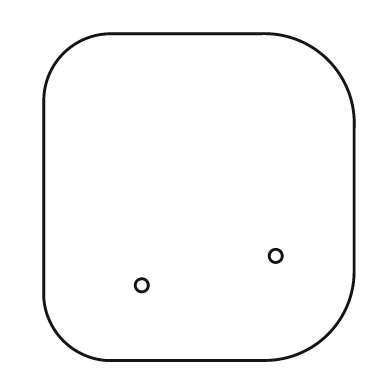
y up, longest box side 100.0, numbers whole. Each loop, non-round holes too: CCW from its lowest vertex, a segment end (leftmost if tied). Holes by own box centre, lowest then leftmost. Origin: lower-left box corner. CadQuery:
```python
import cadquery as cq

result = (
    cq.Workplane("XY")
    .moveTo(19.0, 0.0)
    .lineTo(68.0, 0.0)
    .threePointArc((87.0, 8.0), (95.0, 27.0))
    .lineTo(95.0, 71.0)
    .threePointArc((87.0, 92.0), (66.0, 100.0))
    .lineTo(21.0, 100.0)
    .threePointArc((6.0, 94.0), (0.0, 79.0))
    .lineTo(0.0, 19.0)
    .threePointArc((6.0, 6.0), (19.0, 0.0))
    .close()
    .moveTo(30.0, 23.0)
    .circle(2.0)
    .moveTo(71.0, 32.0)
    .circle(2.0)
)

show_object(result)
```